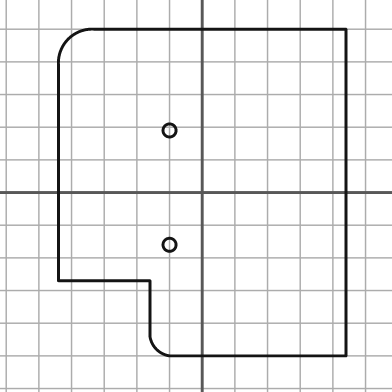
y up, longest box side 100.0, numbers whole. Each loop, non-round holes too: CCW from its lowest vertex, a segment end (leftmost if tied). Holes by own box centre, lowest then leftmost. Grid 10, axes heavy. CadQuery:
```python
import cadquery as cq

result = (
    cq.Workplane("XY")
    .moveTo(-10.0, -50.0)
    .lineTo(44.0, -50.0)
    .lineTo(44.0, 50.0)
    .lineTo(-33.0, 50.0)
    .threePointArc((-41.0, 47.0), (-44.0, 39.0))
    .lineTo(-44.0, -27.0)
    .lineTo(-16.0, -27.0)
    .lineTo(-16.0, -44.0)
    .threePointArc((-14.0, -48.0), (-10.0, -50.0))
    .close()
    .moveTo(-10.0, -16.0)
    .circle(2.0)
    .moveTo(-10.0, 19.0)
    .circle(2.0)
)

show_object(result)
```